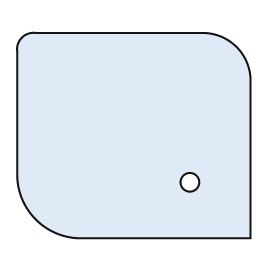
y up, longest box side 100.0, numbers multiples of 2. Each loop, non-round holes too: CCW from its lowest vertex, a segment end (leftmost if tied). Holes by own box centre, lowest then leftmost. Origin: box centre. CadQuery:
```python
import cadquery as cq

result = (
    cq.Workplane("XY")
    .moveTo(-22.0, -44.0)
    .lineTo(50.0, -44.0)
    .lineTo(50.0, 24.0)
    .threePointArc((44.0, 38.0), (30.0, 44.0))
    .lineTo(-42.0, 44.0)
    .threePointArc((-48.0, 42.0), (-50.0, 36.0))
    .lineTo(-50.0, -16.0)
    .threePointArc((-42.0, -36.0), (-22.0, -44.0))
    .close()
    .moveTo(24.0, -20.0)
    .circle(4.0)
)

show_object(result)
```